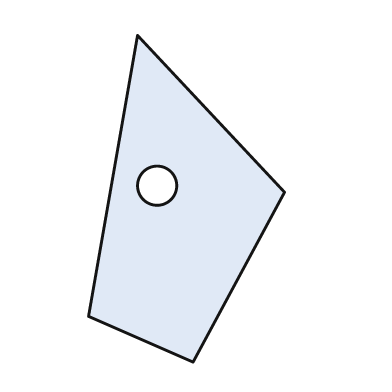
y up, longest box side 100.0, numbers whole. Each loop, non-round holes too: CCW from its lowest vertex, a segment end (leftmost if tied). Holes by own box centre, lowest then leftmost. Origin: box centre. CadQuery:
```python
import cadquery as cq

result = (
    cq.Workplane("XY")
    .moveTo(2.0, -50.0)
    .lineTo(30.0, 2.0)
    .lineTo(-15.0, 50.0)
    .lineTo(-30.0, -36.0)
    .close()
    .moveTo(-9.0, 4.0)
    .circle(6.0)
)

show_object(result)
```